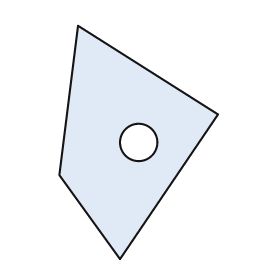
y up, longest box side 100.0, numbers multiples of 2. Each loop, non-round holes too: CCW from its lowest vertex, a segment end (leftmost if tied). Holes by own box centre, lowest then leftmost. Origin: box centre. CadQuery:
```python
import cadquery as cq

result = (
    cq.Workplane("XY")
    .moveTo(-8.0, -50.0)
    .lineTo(34.0, 12.0)
    .lineTo(-26.0, 50.0)
    .lineTo(-34.0, -14.0)
    .close()
    .moveTo(0.0, 0.0)
    .circle(8.0)
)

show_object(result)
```